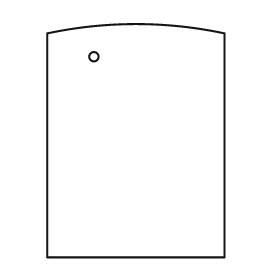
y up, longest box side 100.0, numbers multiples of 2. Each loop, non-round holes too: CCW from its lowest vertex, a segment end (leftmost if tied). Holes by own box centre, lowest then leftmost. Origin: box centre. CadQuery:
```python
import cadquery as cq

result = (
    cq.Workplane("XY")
    .moveTo(-38.0, -50.0)
    .lineTo(38.0, -50.0)
    .lineTo(38.0, 46.0)
    .threePointArc((0.0, 50.0), (-38.0, 46.0))
    .close()
    .moveTo(-18.0, 36.0)
    .circle(2.0)
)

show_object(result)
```